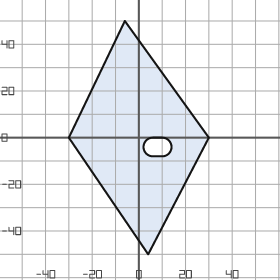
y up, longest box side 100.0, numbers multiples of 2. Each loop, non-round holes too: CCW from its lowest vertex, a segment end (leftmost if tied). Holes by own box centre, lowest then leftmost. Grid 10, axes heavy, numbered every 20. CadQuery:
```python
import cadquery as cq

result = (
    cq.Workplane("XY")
    .moveTo(4.0, -50.0)
    .lineTo(30.0, 0.0)
    .lineTo(-6.0, 50.0)
    .lineTo(-30.0, 0.0)
    .close()
    .moveTo(6.0, -8.0)
    .lineTo(10.0, -8.0)
    .threePointArc((14.0, -4.0), (10.0, 0.0))
    .lineTo(6.0, 0.0)
    .threePointArc((2.0, -4.0), (6.0, -8.0))
    .close()
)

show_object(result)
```